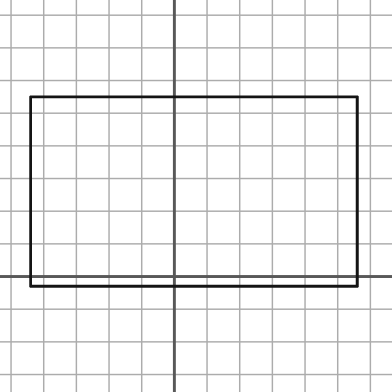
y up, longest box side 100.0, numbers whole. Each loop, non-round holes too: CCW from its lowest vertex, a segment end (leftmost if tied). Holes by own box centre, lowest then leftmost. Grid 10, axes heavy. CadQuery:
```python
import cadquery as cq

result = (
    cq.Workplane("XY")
    .moveTo(-44.0, -3.0)
    .lineTo(56.0, -3.0)
    .lineTo(56.0, 55.0)
    .lineTo(-44.0, 55.0)
    .close()
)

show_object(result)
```